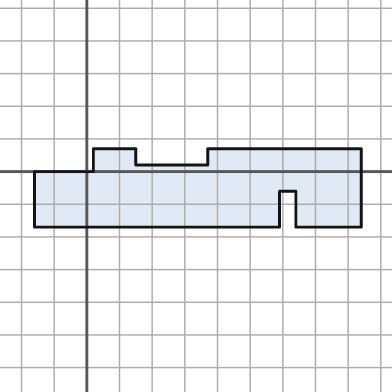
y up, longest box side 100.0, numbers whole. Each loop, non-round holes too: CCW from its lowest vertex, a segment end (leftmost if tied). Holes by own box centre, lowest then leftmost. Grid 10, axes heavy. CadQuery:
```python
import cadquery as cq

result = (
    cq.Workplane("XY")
    .moveTo(-16.0, -17.0)
    .lineTo(59.0, -17.0)
    .lineTo(59.0, -6.0)
    .lineTo(64.0, -6.0)
    .lineTo(64.0, -17.0)
    .lineTo(84.0, -17.0)
    .lineTo(84.0, 7.0)
    .lineTo(37.0, 7.0)
    .lineTo(37.0, 2.0)
    .lineTo(15.0, 2.0)
    .lineTo(15.0, 7.0)
    .lineTo(2.0, 7.0)
    .lineTo(2.0, 0.0)
    .lineTo(-16.0, 0.0)
    .close()
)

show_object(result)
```